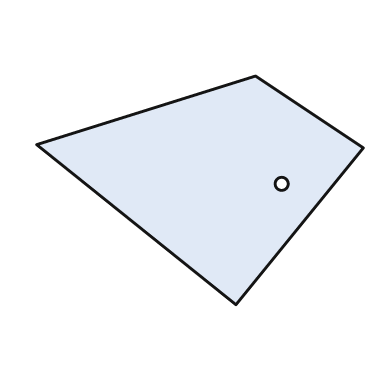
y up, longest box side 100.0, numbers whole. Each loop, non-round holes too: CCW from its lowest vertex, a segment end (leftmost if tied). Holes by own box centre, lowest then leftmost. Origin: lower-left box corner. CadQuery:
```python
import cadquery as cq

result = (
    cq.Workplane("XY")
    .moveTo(61.0, 0.0)
    .lineTo(100.0, 48.0)
    .lineTo(67.0, 70.0)
    .lineTo(0.0, 49.0)
    .close()
    .moveTo(75.0, 37.0)
    .circle(2.0)
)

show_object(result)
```